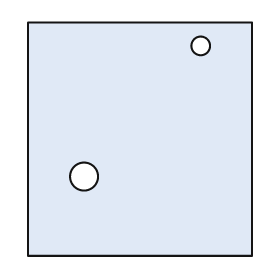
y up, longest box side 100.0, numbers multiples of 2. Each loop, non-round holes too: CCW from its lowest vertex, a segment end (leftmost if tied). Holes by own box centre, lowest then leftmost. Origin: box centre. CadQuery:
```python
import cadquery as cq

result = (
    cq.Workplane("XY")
    .moveTo(-48.0, -50.0)
    .lineTo(48.0, -50.0)
    .lineTo(48.0, 50.0)
    .lineTo(-48.0, 50.0)
    .close()
    .moveTo(-24.0, -16.0)
    .circle(6.0)
    .moveTo(26.0, 40.0)
    .circle(4.0)
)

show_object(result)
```